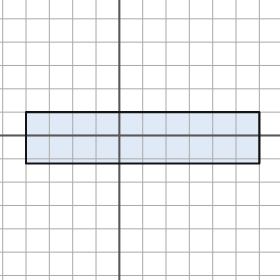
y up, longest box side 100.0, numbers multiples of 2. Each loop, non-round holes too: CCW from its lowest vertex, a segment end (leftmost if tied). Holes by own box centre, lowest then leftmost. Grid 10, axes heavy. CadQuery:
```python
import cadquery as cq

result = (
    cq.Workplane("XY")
    .moveTo(-40.0, -12.0)
    .lineTo(60.0, -12.0)
    .lineTo(60.0, 10.0)
    .lineTo(-40.0, 10.0)
    .close()
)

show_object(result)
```